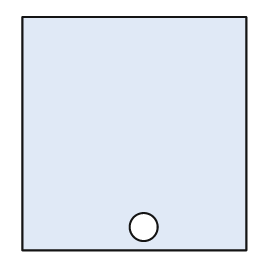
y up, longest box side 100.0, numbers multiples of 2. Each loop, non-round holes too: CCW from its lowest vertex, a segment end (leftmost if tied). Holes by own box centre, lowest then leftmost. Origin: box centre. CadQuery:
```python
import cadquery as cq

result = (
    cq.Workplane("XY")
    .moveTo(-48.0, -50.0)
    .lineTo(48.0, -50.0)
    .lineTo(48.0, 50.0)
    .lineTo(-48.0, 50.0)
    .close()
    .moveTo(4.0, -40.0)
    .circle(6.0)
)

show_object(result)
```